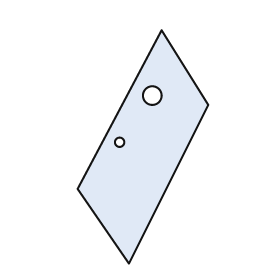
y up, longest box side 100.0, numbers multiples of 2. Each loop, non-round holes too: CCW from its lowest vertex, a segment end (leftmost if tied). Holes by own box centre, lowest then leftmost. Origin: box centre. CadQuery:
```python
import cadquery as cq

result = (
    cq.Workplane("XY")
    .moveTo(-6.0, -50.0)
    .lineTo(28.0, 18.0)
    .lineTo(8.0, 50.0)
    .lineTo(-28.0, -18.0)
    .close()
    .moveTo(-10.0, 2.0)
    .circle(2.0)
    .moveTo(4.0, 22.0)
    .circle(4.0)
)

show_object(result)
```